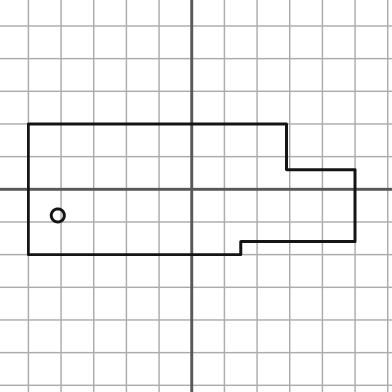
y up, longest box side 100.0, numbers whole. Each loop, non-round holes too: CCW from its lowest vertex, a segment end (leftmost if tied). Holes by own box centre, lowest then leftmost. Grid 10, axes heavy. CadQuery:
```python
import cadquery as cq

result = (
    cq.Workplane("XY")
    .moveTo(-50.0, -20.0)
    .lineTo(15.0, -20.0)
    .lineTo(15.0, -16.0)
    .lineTo(50.0, -16.0)
    .lineTo(50.0, 6.0)
    .lineTo(29.0, 6.0)
    .lineTo(29.0, 20.0)
    .lineTo(-50.0, 20.0)
    .close()
    .moveTo(-41.0, -8.0)
    .circle(2.0)
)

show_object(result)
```